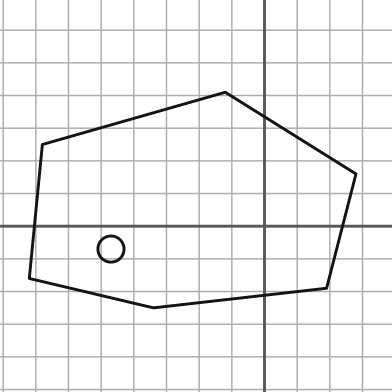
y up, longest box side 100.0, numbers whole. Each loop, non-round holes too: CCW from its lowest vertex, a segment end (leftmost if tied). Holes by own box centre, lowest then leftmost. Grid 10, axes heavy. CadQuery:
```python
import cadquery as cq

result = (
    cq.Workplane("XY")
    .moveTo(-34.0, -25.0)
    .lineTo(19.0, -19.0)
    .lineTo(28.0, 16.0)
    .lineTo(-12.0, 41.0)
    .lineTo(-68.0, 25.0)
    .lineTo(-72.0, -16.0)
    .close()
    .moveTo(-47.0, -7.0)
    .circle(4.0)
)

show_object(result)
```